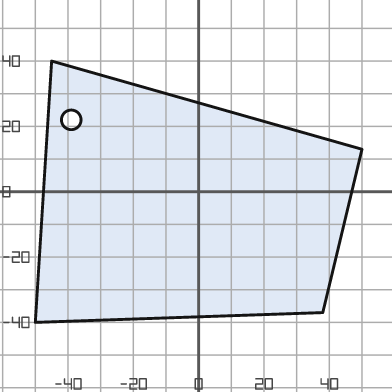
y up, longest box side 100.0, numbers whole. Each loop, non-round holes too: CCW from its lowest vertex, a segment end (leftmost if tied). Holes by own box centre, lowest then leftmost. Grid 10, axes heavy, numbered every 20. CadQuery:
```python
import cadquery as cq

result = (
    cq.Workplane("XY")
    .moveTo(-50.0, -40.0)
    .lineTo(38.0, -37.0)
    .lineTo(50.0, 13.0)
    .lineTo(-45.0, 40.0)
    .close()
    .moveTo(-39.0, 22.0)
    .circle(3.0)
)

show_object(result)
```